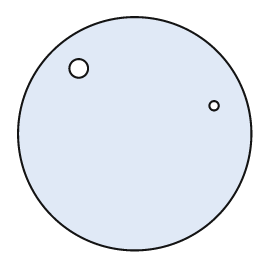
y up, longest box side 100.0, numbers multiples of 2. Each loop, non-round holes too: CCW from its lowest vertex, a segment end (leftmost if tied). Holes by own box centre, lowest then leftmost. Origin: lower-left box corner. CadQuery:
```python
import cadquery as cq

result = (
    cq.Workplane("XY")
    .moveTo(50.0, 50.0)
    .circle(50.0)
    .moveTo(84.0, 62.0)
    .circle(2.0)
    .moveTo(26.0, 78.0)
    .circle(4.0)
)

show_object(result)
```